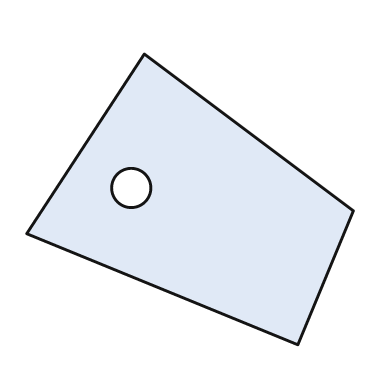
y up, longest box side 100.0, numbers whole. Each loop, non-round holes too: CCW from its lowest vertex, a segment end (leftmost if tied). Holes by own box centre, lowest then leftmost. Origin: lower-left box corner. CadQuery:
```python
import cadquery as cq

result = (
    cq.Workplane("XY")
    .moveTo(83.0, 0.0)
    .lineTo(100.0, 41.0)
    .lineTo(36.0, 89.0)
    .lineTo(0.0, 34.0)
    .close()
    .moveTo(32.0, 48.0)
    .circle(6.0)
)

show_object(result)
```